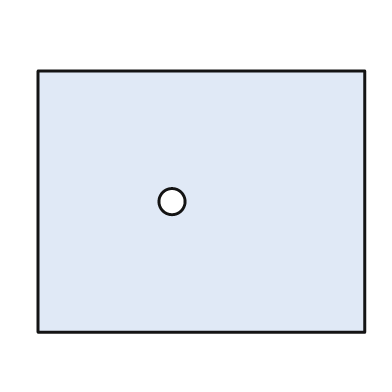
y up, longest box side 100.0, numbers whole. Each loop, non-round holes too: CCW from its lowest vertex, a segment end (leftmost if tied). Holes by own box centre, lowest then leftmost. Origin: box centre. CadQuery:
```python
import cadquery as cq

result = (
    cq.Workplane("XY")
    .moveTo(-50.0, -40.0)
    .lineTo(50.0, -40.0)
    .lineTo(50.0, 40.0)
    .lineTo(-50.0, 40.0)
    .close()
    .moveTo(-9.0, 0.0)
    .circle(4.0)
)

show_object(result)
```